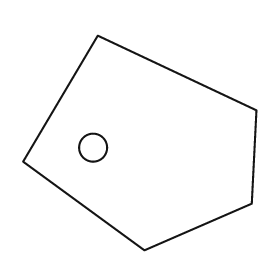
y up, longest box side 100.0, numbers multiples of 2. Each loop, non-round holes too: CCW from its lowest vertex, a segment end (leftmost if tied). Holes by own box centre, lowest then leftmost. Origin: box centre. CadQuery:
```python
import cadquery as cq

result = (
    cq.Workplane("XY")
    .moveTo(2.0, -46.0)
    .lineTo(48.0, -26.0)
    .lineTo(50.0, 14.0)
    .lineTo(-18.0, 46.0)
    .lineTo(-50.0, -8.0)
    .close()
    .moveTo(-20.0, -2.0)
    .circle(6.0)
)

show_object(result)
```